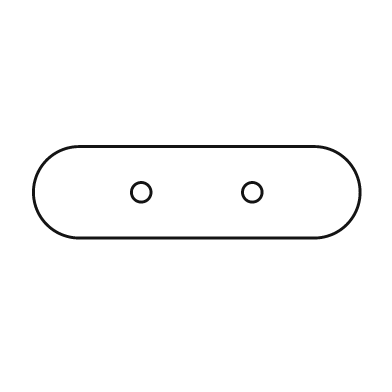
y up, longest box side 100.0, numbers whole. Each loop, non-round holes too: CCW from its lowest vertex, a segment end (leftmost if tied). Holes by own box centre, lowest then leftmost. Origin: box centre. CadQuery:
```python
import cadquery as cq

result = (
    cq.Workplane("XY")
    .moveTo(-36.0, -14.0)
    .lineTo(36.0, -14.0)
    .threePointArc((50.0, 0.0), (36.0, 14.0))
    .lineTo(-36.0, 14.0)
    .threePointArc((-50.0, 0.0), (-36.0, -14.0))
    .close()
    .moveTo(-17.0, 0.0)
    .circle(3.0)
    .moveTo(17.0, 0.0)
    .circle(3.0)
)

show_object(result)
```